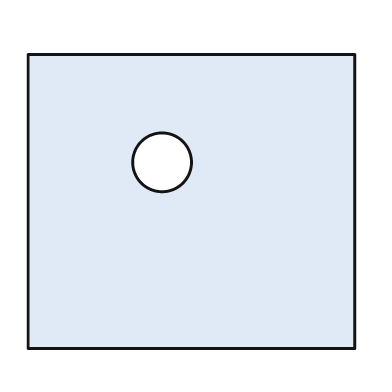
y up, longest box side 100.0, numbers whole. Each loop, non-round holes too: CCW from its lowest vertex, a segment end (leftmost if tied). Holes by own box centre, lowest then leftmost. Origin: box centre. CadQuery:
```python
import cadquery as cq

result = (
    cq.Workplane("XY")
    .moveTo(-50.0, -45.0)
    .lineTo(50.0, -45.0)
    .lineTo(50.0, 45.0)
    .lineTo(-50.0, 45.0)
    .close()
    .moveTo(-9.0, 12.0)
    .circle(9.0)
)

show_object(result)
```